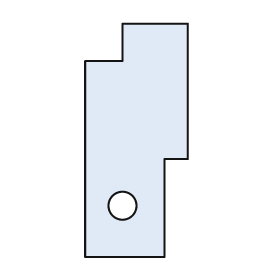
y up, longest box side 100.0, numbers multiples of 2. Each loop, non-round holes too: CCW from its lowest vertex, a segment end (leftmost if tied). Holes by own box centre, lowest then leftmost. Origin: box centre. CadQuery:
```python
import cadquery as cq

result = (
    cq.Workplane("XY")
    .moveTo(-22.0, -50.0)
    .lineTo(12.0, -50.0)
    .lineTo(12.0, -8.0)
    .lineTo(22.0, -8.0)
    .lineTo(22.0, 50.0)
    .lineTo(-6.0, 50.0)
    .lineTo(-6.0, 34.0)
    .lineTo(-22.0, 34.0)
    .close()
    .moveTo(-6.0, -28.0)
    .circle(6.0)
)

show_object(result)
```